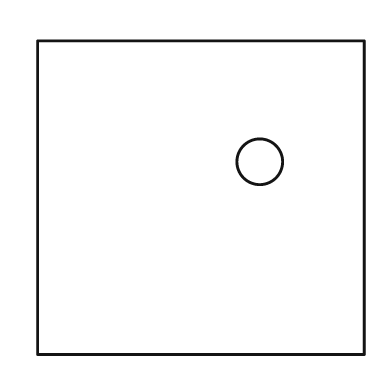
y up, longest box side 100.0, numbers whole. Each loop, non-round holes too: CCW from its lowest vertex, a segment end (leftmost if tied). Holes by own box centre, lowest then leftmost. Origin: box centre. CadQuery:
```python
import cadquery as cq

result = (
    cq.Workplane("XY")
    .moveTo(-50.0, -48.0)
    .lineTo(50.0, -48.0)
    .lineTo(50.0, 48.0)
    .lineTo(-50.0, 48.0)
    .close()
    .moveTo(18.0, 11.0)
    .circle(7.0)
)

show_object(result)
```